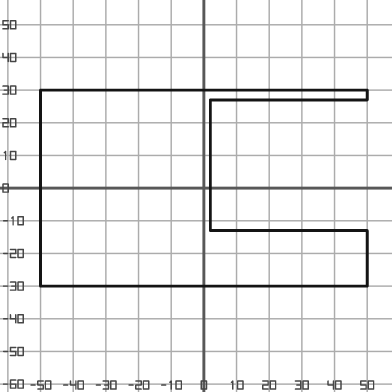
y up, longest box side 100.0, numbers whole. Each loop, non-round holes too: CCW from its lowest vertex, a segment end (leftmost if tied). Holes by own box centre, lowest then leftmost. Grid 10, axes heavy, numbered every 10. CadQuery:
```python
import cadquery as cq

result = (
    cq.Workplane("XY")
    .moveTo(-50.0, -30.0)
    .lineTo(50.0, -30.0)
    .lineTo(50.0, -13.0)
    .lineTo(2.0, -13.0)
    .lineTo(2.0, 27.0)
    .lineTo(50.0, 27.0)
    .lineTo(50.0, 30.0)
    .lineTo(-50.0, 30.0)
    .close()
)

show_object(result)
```